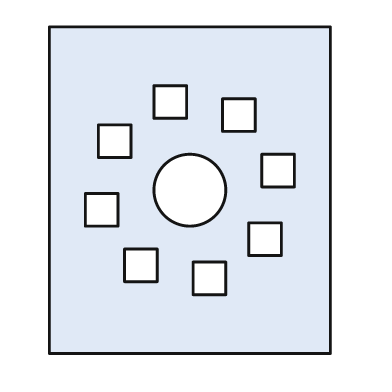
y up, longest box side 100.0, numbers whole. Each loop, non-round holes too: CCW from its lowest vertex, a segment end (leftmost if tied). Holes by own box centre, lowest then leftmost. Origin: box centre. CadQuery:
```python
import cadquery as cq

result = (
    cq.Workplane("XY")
    .moveTo(-43.0, -50.0)
    .lineTo(43.0, -50.0)
    .lineTo(43.0, 50.0)
    .lineTo(-43.0, 50.0)
    .close()
    .moveTo(1.0, -32.0)
    .lineTo(11.0, -32.0)
    .lineTo(11.0, -22.0)
    .lineTo(1.0, -22.0)
    .close()
    .moveTo(-20.0, -28.0)
    .lineTo(-10.0, -28.0)
    .lineTo(-10.0, -18.0)
    .lineTo(-20.0, -18.0)
    .close()
    .moveTo(18.0, -20.0)
    .lineTo(28.0, -20.0)
    .lineTo(28.0, -10.0)
    .lineTo(18.0, -10.0)
    .close()
    .moveTo(-32.0, -11.0)
    .lineTo(-22.0, -11.0)
    .lineTo(-22.0, -1.0)
    .lineTo(-32.0, -1.0)
    .close()
    .moveTo(0.0, 0.0)
    .circle(11.0)
    .moveTo(22.0, 1.0)
    .lineTo(32.0, 1.0)
    .lineTo(32.0, 11.0)
    .lineTo(22.0, 11.0)
    .close()
    .moveTo(-28.0, 10.0)
    .lineTo(-18.0, 10.0)
    .lineTo(-18.0, 20.0)
    .lineTo(-28.0, 20.0)
    .close()
    .moveTo(10.0, 18.0)
    .lineTo(20.0, 18.0)
    .lineTo(20.0, 28.0)
    .lineTo(10.0, 28.0)
    .close()
    .moveTo(-11.0, 22.0)
    .lineTo(-1.0, 22.0)
    .lineTo(-1.0, 32.0)
    .lineTo(-11.0, 32.0)
    .close()
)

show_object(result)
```